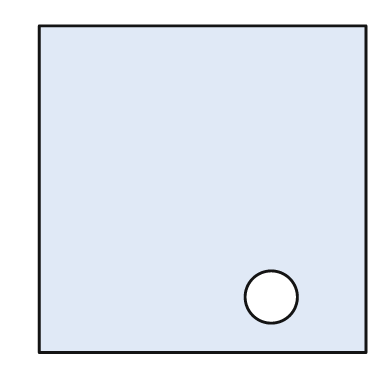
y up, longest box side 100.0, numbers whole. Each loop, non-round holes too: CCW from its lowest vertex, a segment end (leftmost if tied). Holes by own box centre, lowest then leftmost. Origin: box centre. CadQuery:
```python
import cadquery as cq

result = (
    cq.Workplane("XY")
    .moveTo(-50.0, -50.0)
    .lineTo(50.0, -50.0)
    .lineTo(50.0, 50.0)
    .lineTo(-50.0, 50.0)
    .close()
    .moveTo(21.0, -33.0)
    .circle(8.0)
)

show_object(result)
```